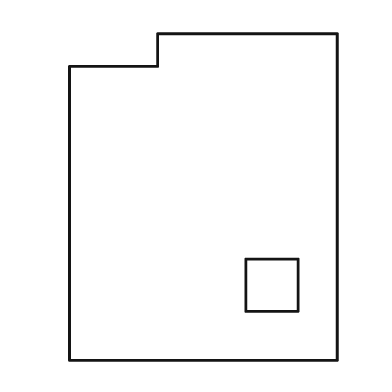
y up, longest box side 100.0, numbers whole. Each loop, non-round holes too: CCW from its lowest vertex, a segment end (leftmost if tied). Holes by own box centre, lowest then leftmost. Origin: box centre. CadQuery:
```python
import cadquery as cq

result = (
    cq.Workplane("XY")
    .moveTo(-41.0, -50.0)
    .lineTo(41.0, -50.0)
    .lineTo(41.0, 50.0)
    .lineTo(-14.0, 50.0)
    .lineTo(-14.0, 40.0)
    .lineTo(-41.0, 40.0)
    .close()
    .moveTo(13.0, -35.0)
    .lineTo(29.0, -35.0)
    .lineTo(29.0, -19.0)
    .lineTo(13.0, -19.0)
    .close()
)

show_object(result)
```